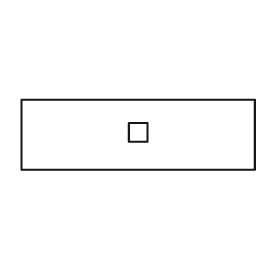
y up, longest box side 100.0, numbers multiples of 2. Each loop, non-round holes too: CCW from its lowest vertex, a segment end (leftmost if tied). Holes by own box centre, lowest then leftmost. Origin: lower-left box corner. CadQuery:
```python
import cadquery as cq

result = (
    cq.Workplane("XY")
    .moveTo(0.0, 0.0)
    .lineTo(100.0, 0.0)
    .lineTo(100.0, 30.0)
    .lineTo(0.0, 30.0)
    .close()
    .moveTo(46.0, 12.0)
    .lineTo(54.0, 12.0)
    .lineTo(54.0, 20.0)
    .lineTo(46.0, 20.0)
    .close()
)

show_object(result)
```